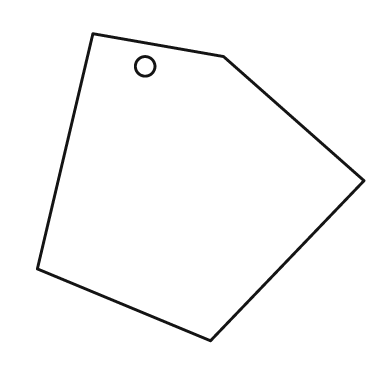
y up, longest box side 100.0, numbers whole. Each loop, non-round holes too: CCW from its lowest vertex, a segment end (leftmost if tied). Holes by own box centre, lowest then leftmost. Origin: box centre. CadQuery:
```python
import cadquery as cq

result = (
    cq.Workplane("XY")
    .moveTo(3.0, -47.0)
    .lineTo(50.0, 2.0)
    .lineTo(7.0, 40.0)
    .lineTo(-33.0, 47.0)
    .lineTo(-50.0, -25.0)
    .close()
    .moveTo(-17.0, 37.0)
    .circle(3.0)
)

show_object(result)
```